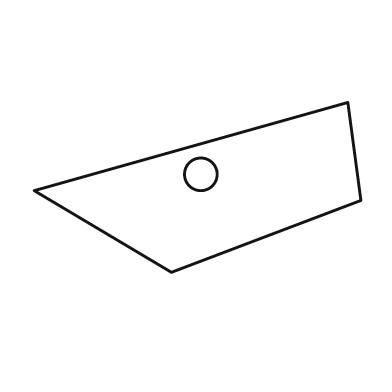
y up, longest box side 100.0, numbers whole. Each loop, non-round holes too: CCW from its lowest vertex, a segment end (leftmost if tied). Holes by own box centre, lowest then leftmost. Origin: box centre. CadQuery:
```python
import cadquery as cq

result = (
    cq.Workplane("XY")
    .moveTo(-8.0, -26.0)
    .lineTo(50.0, -4.0)
    .lineTo(46.0, 26.0)
    .lineTo(-50.0, -1.0)
    .close()
    .moveTo(1.0, 4.0)
    .circle(5.0)
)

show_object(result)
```